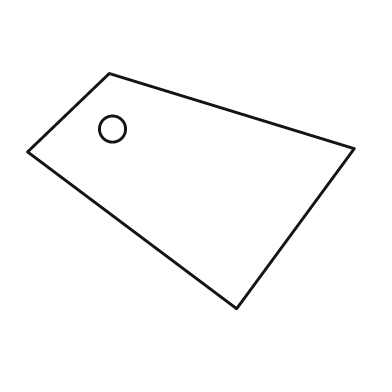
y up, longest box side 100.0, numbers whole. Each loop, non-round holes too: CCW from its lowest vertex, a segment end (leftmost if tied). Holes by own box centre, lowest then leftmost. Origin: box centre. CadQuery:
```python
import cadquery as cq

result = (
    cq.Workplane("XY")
    .moveTo(14.0, -36.0)
    .lineTo(50.0, 13.0)
    .lineTo(-25.0, 36.0)
    .lineTo(-50.0, 12.0)
    .close()
    .moveTo(-24.0, 19.0)
    .circle(4.0)
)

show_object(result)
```